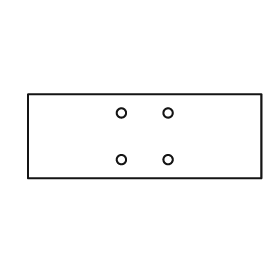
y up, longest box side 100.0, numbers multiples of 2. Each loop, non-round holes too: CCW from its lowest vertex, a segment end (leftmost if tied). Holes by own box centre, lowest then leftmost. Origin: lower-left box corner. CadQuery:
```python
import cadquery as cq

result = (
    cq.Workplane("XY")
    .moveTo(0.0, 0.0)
    .lineTo(100.0, 0.0)
    .lineTo(100.0, 36.0)
    .lineTo(0.0, 36.0)
    .close()
    .moveTo(40.0, 8.0)
    .circle(2.0)
    .moveTo(60.0, 8.0)
    .circle(2.0)
    .moveTo(40.0, 28.0)
    .circle(2.0)
    .moveTo(60.0, 28.0)
    .circle(2.0)
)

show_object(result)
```